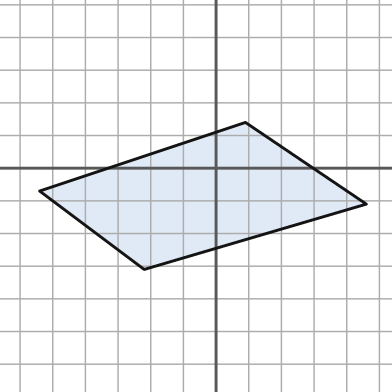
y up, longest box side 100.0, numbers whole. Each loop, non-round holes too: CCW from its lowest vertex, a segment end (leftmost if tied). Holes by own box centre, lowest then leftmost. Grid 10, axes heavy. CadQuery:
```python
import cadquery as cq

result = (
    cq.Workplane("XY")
    .moveTo(-22.0, -31.0)
    .lineTo(46.0, -11.0)
    .lineTo(9.0, 14.0)
    .lineTo(-54.0, -7.0)
    .close()
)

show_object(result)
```